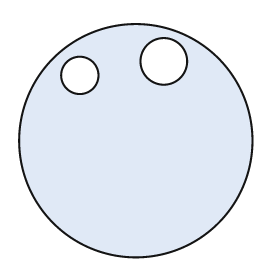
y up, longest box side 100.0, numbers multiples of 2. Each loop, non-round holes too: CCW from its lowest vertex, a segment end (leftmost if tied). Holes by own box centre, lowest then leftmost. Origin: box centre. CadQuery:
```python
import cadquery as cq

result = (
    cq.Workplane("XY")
    .moveTo(0.0, 0.0)
    .circle(50.0)
    .moveTo(-24.0, 28.0)
    .circle(8.0)
    .moveTo(12.0, 34.0)
    .circle(10.0)
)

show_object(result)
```